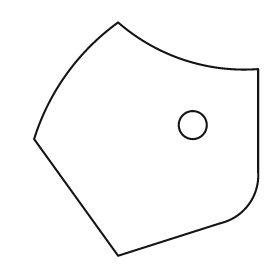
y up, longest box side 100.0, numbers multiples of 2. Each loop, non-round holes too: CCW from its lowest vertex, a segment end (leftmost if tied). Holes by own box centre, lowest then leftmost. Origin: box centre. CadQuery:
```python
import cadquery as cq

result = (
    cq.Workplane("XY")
    .moveTo(-12.0, -50.0)
    .lineTo(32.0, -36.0)
    .threePointArc((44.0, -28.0), (48.0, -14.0))
    .lineTo(48.0, 30.0)
    .threePointArc((16.0, 34.0), (-12.0, 50.0))
    .threePointArc((-34.0, 28.0), (-48.0, 0.0))
    .close()
    .moveTo(20.0, 6.0)
    .circle(6.0)
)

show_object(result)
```